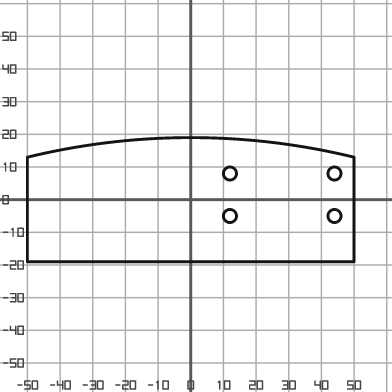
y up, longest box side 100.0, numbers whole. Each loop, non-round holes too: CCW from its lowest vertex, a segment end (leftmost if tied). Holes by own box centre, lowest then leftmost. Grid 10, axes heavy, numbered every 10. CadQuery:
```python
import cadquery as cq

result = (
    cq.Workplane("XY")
    .moveTo(-50.0, -19.0)
    .lineTo(50.0, -19.0)
    .lineTo(50.0, 13.0)
    .threePointArc((0.0, 19.0), (-50.0, 13.0))
    .close()
    .moveTo(12.0, -5.0)
    .circle(2.0)
    .moveTo(44.0, -5.0)
    .circle(2.0)
    .moveTo(12.0, 8.0)
    .circle(2.0)
    .moveTo(44.0, 8.0)
    .circle(2.0)
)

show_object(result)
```